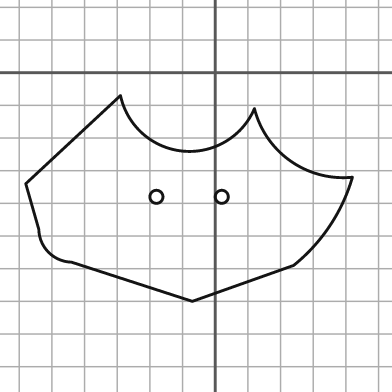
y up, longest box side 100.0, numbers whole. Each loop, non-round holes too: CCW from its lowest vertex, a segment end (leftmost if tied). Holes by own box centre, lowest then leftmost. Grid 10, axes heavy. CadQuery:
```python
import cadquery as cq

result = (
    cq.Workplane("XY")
    .moveTo(-7.0, -70.0)
    .lineTo(24.0, -59.0)
    .threePointArc((35.0, -47.0), (42.0, -32.0))
    .threePointArc((23.0, -27.0), (12.0, -11.0))
    .threePointArc((-10.0, -24.0), (-29.0, -7.0))
    .lineTo(-58.0, -34.0)
    .lineTo(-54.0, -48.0)
    .threePointArc((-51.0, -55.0), (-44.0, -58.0))
    .close()
    .moveTo(-18.0, -38.0)
    .circle(2.0)
    .moveTo(2.0, -38.0)
    .circle(2.0)
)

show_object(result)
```